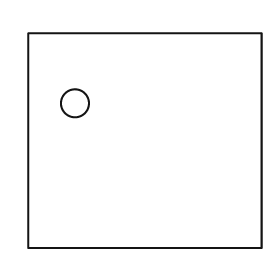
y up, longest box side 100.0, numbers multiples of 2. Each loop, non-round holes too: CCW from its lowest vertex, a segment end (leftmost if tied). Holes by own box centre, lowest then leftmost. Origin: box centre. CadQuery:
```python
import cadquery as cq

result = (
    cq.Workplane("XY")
    .moveTo(-50.0, -46.0)
    .lineTo(50.0, -46.0)
    .lineTo(50.0, 46.0)
    .lineTo(-50.0, 46.0)
    .close()
    .moveTo(-30.0, 16.0)
    .circle(6.0)
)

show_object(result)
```